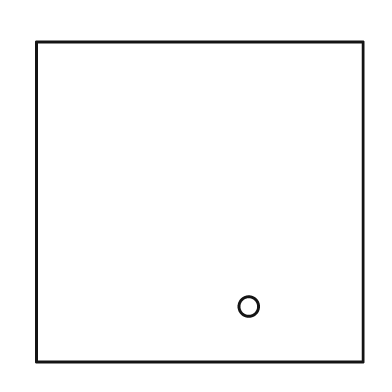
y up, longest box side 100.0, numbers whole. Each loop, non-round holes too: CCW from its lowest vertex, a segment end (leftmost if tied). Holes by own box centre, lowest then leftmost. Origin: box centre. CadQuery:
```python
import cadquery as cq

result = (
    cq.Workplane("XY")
    .moveTo(-50.0, -49.0)
    .lineTo(50.0, -49.0)
    .lineTo(50.0, 49.0)
    .lineTo(-50.0, 49.0)
    .close()
    .moveTo(15.0, -32.0)
    .circle(3.0)
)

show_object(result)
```